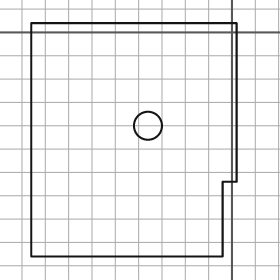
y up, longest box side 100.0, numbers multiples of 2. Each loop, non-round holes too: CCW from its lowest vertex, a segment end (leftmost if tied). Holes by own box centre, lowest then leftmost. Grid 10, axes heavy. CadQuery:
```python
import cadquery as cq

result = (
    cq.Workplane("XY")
    .moveTo(-86.0, -96.0)
    .lineTo(-4.0, -96.0)
    .lineTo(-4.0, -64.0)
    .lineTo(2.0, -64.0)
    .lineTo(2.0, 4.0)
    .lineTo(-86.0, 4.0)
    .close()
    .moveTo(-36.0, -40.0)
    .circle(6.0)
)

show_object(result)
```